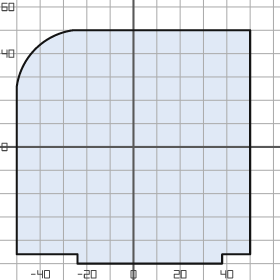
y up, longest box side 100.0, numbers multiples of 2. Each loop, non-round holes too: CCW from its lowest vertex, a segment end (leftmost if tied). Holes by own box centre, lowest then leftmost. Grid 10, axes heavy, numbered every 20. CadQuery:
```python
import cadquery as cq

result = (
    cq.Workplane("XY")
    .moveTo(-24.0, -50.0)
    .lineTo(38.0, -50.0)
    .lineTo(38.0, -46.0)
    .lineTo(50.0, -46.0)
    .lineTo(50.0, 50.0)
    .lineTo(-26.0, 50.0)
    .threePointArc((-42.0, 42.0), (-50.0, 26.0))
    .lineTo(-50.0, -46.0)
    .lineTo(-24.0, -46.0)
    .close()
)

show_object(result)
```